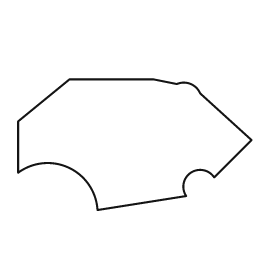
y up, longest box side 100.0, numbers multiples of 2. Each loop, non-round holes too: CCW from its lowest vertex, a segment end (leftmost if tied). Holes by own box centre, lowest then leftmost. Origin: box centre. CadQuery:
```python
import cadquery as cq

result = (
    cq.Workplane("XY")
    .moveTo(-16.0, -28.0)
    .lineTo(22.0, -22.0)
    .threePointArc((24.0, -12.0), (34.0, -14.0))
    .lineTo(50.0, 2.0)
    .lineTo(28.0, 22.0)
    .threePointArc((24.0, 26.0), (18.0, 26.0))
    .lineTo(8.0, 28.0)
    .lineTo(-28.0, 28.0)
    .lineTo(-50.0, 10.0)
    .lineTo(-50.0, -12.0)
    .threePointArc((-28.0, -10.0), (-16.0, -28.0))
    .close()
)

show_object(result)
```